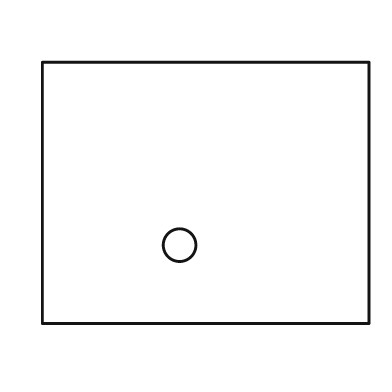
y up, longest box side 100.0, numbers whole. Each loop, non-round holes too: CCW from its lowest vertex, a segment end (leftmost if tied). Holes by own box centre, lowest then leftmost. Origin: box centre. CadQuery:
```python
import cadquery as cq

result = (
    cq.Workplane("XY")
    .moveTo(-50.0, -40.0)
    .lineTo(50.0, -40.0)
    .lineTo(50.0, 40.0)
    .lineTo(-50.0, 40.0)
    .close()
    .moveTo(-8.0, -16.0)
    .circle(5.0)
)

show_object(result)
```